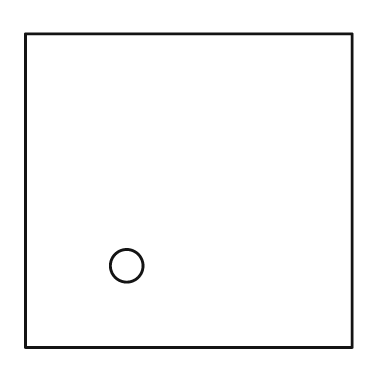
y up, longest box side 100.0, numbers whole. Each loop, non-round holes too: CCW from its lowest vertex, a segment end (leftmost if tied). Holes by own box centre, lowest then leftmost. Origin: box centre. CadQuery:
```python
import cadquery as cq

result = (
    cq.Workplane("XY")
    .moveTo(-50.0, -48.0)
    .lineTo(50.0, -48.0)
    .lineTo(50.0, 48.0)
    .lineTo(-50.0, 48.0)
    .close()
    .moveTo(-19.0, -23.0)
    .circle(5.0)
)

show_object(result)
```